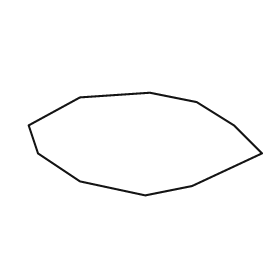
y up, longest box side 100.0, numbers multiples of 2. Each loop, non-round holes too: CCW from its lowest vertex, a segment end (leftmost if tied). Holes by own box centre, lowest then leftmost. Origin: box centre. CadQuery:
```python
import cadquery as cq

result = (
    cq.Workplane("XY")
    .moveTo(0.0, -22.0)
    .lineTo(20.0, -18.0)
    .lineTo(50.0, -4.0)
    .lineTo(38.0, 8.0)
    .lineTo(22.0, 18.0)
    .lineTo(2.0, 22.0)
    .lineTo(-28.0, 20.0)
    .lineTo(-50.0, 8.0)
    .lineTo(-46.0, -4.0)
    .lineTo(-28.0, -16.0)
    .close()
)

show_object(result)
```